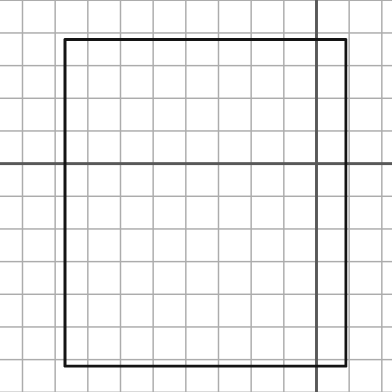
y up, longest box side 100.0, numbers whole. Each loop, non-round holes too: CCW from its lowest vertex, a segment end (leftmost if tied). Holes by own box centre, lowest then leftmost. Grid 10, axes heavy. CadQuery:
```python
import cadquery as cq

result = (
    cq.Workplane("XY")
    .moveTo(-77.0, -62.0)
    .lineTo(9.0, -62.0)
    .lineTo(9.0, 38.0)
    .lineTo(-77.0, 38.0)
    .close()
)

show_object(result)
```